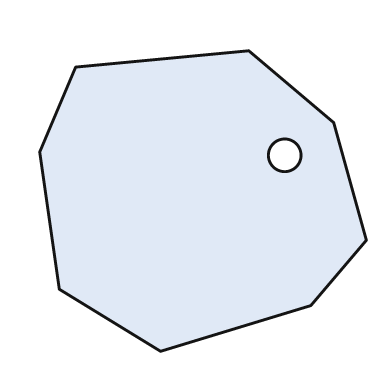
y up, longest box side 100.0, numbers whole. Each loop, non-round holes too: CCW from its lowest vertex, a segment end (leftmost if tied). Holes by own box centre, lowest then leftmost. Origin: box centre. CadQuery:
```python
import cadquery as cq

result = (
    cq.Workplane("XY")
    .moveTo(-13.0, -46.0)
    .lineTo(33.0, -32.0)
    .lineTo(50.0, -12.0)
    .lineTo(40.0, 24.0)
    .lineTo(14.0, 46.0)
    .lineTo(-39.0, 41.0)
    .lineTo(-50.0, 15.0)
    .lineTo(-44.0, -27.0)
    .close()
    .moveTo(25.0, 14.0)
    .circle(5.0)
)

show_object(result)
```